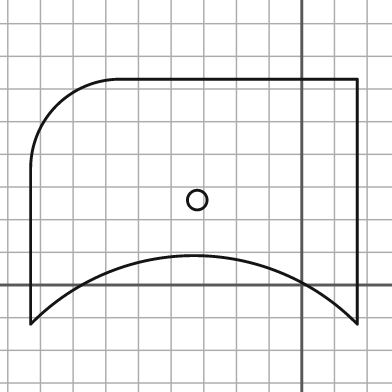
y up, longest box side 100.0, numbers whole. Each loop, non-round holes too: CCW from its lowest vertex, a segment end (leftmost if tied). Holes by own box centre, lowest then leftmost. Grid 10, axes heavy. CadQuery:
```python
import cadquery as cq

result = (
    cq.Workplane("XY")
    .moveTo(-83.0, -12.0)
    .threePointArc((-33.0, 9.0), (17.0, -12.0))
    .lineTo(17.0, 63.0)
    .lineTo(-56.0, 63.0)
    .threePointArc((-75.0, 55.0), (-83.0, 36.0))
    .close()
    .moveTo(-32.0, 26.0)
    .circle(3.0)
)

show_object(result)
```